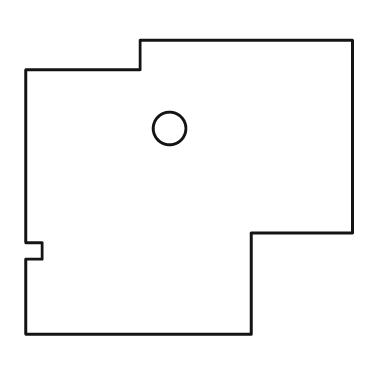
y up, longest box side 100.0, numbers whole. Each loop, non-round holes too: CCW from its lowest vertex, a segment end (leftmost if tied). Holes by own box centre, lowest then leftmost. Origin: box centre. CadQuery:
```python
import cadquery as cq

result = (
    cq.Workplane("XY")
    .moveTo(-50.0, -45.0)
    .lineTo(19.0, -45.0)
    .lineTo(19.0, -14.0)
    .lineTo(50.0, -14.0)
    .lineTo(50.0, 45.0)
    .lineTo(-15.0, 45.0)
    .lineTo(-15.0, 36.0)
    .lineTo(-50.0, 36.0)
    .lineTo(-50.0, -17.0)
    .lineTo(-45.0, -17.0)
    .lineTo(-45.0, -22.0)
    .lineTo(-50.0, -22.0)
    .close()
    .moveTo(-6.0, 18.0)
    .circle(5.0)
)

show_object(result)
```